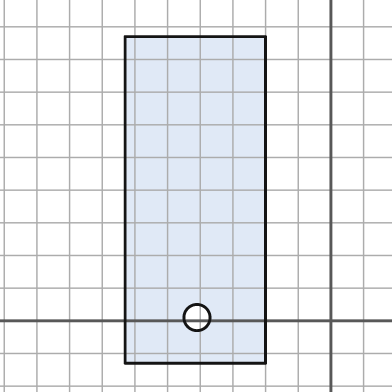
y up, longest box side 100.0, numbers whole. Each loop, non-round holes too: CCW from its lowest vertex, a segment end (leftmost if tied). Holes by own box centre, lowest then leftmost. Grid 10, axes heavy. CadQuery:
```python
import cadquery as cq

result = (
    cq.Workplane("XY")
    .moveTo(-63.0, -13.0)
    .lineTo(-20.0, -13.0)
    .lineTo(-20.0, 87.0)
    .lineTo(-63.0, 87.0)
    .close()
    .moveTo(-41.0, 1.0)
    .circle(4.0)
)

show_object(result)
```